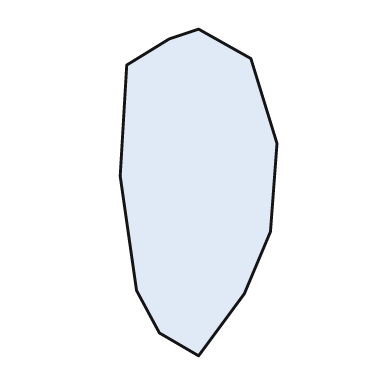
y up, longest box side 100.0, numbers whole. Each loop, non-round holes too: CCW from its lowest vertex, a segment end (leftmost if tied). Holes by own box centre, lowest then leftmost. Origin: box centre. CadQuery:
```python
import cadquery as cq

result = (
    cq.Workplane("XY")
    .moveTo(0.0, -50.0)
    .lineTo(14.0, -31.0)
    .lineTo(22.0, -12.0)
    .lineTo(24.0, 15.0)
    .lineTo(16.0, 41.0)
    .lineTo(0.0, 50.0)
    .lineTo(-9.0, 47.0)
    .lineTo(-22.0, 39.0)
    .lineTo(-24.0, 5.0)
    .lineTo(-19.0, -30.0)
    .lineTo(-12.0, -43.0)
    .close()
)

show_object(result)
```